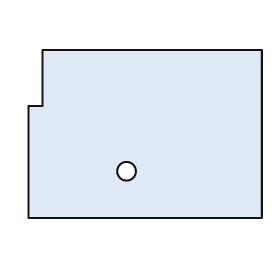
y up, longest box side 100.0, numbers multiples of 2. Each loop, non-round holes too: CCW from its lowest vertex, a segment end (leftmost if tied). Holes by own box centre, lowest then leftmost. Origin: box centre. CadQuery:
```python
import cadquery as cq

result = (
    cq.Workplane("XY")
    .moveTo(-50.0, -36.0)
    .lineTo(50.0, -36.0)
    .lineTo(50.0, 36.0)
    .lineTo(-44.0, 36.0)
    .lineTo(-44.0, 12.0)
    .lineTo(-50.0, 12.0)
    .close()
    .moveTo(-8.0, -16.0)
    .circle(4.0)
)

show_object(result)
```